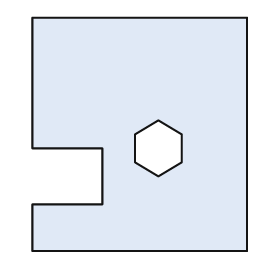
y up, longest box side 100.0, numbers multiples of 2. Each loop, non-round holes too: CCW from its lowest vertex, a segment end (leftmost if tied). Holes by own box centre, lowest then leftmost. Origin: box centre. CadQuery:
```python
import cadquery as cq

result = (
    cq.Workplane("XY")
    .moveTo(-46.0, -50.0)
    .lineTo(46.0, -50.0)
    .lineTo(46.0, 50.0)
    .lineTo(-46.0, 50.0)
    .lineTo(-46.0, -6.0)
    .lineTo(-16.0, -6.0)
    .lineTo(-16.0, -30.0)
    .lineTo(-46.0, -30.0)
    .close()
    .moveTo(8.0, -18.0)
    .lineTo(18.0, -12.0)
    .lineTo(18.0, 0.0)
    .lineTo(8.0, 6.0)
    .lineTo(-2.0, 0.0)
    .lineTo(-2.0, -12.0)
    .close()
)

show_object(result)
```